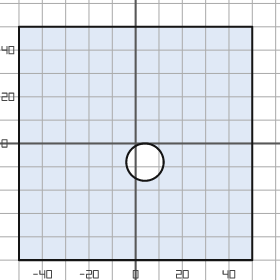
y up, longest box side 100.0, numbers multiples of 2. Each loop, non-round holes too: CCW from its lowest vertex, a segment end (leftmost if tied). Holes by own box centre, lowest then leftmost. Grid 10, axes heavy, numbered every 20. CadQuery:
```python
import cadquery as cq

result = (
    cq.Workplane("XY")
    .moveTo(-50.0, -50.0)
    .lineTo(50.0, -50.0)
    .lineTo(50.0, 50.0)
    .lineTo(-50.0, 50.0)
    .close()
    .moveTo(4.0, -8.0)
    .circle(8.0)
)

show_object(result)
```